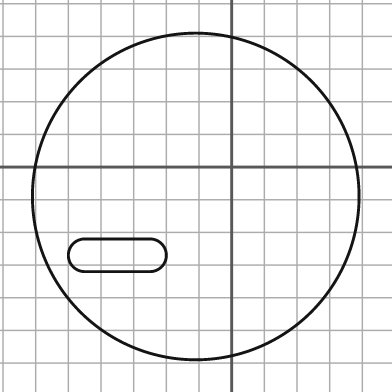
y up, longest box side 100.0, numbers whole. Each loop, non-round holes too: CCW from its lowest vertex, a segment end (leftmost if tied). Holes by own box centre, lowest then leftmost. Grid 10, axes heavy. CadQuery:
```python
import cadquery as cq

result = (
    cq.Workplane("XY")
    .moveTo(-11.0, -9.0)
    .circle(50.0)
    .moveTo(-45.0, -32.0)
    .lineTo(-25.0, -32.0)
    .threePointArc((-20.0, -27.0), (-25.0, -22.0))
    .lineTo(-45.0, -22.0)
    .threePointArc((-50.0, -27.0), (-45.0, -32.0))
    .close()
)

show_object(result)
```